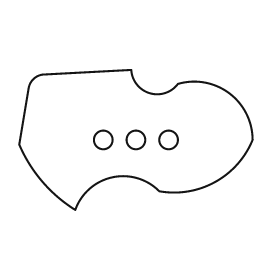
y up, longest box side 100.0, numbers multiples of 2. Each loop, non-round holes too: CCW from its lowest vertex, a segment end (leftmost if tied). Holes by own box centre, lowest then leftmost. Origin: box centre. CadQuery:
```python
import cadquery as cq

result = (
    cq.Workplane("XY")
    .moveTo(-26.0, -30.0)
    .threePointArc((-10.0, -16.0), (10.0, -22.0))
    .threePointArc((34.0, -18.0), (50.0, 0.0))
    .threePointArc((40.0, 20.0), (18.0, 24.0))
    .threePointArc((6.0, 20.0), (-2.0, 30.0))
    .lineTo(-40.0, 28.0)
    .threePointArc((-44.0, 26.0), (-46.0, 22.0))
    .lineTo(-50.0, -2.0)
    .threePointArc((-40.0, -18.0), (-26.0, -30.0))
    .close()
    .moveTo(-14.0, 0.0)
    .circle(4.0)
    .moveTo(0.0, 0.0)
    .circle(4.0)
    .moveTo(14.0, 0.0)
    .circle(4.0)
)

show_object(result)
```